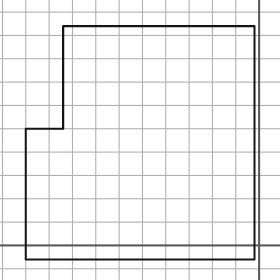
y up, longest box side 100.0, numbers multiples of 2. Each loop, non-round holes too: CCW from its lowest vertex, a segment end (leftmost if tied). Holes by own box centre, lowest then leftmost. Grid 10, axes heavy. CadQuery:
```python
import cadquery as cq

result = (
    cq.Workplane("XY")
    .moveTo(-100.0, -6.0)
    .lineTo(-2.0, -6.0)
    .lineTo(-2.0, 94.0)
    .lineTo(-84.0, 94.0)
    .lineTo(-84.0, 50.0)
    .lineTo(-100.0, 50.0)
    .close()
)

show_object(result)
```